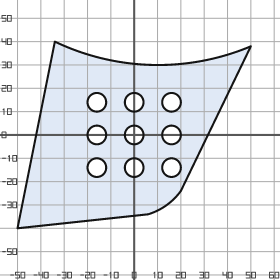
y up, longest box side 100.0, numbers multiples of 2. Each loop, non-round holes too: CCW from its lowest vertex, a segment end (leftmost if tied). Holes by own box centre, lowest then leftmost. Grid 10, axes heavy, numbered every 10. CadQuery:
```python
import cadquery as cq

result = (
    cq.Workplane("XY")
    .moveTo(-50.0, -40.0)
    .lineTo(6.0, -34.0)
    .threePointArc((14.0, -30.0), (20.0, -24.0))
    .lineTo(50.0, 38.0)
    .threePointArc((8.0, 30.0), (-34.0, 40.0))
    .close()
    .moveTo(-16.0, -14.0)
    .circle(4.0)
    .moveTo(0.0, -14.0)
    .circle(4.0)
    .moveTo(16.0, -14.0)
    .circle(4.0)
    .moveTo(-16.0, 0.0)
    .circle(4.0)
    .moveTo(0.0, 0.0)
    .circle(4.0)
    .moveTo(16.0, 0.0)
    .circle(4.0)
    .moveTo(-16.0, 14.0)
    .circle(4.0)
    .moveTo(0.0, 14.0)
    .circle(4.0)
    .moveTo(16.0, 14.0)
    .circle(4.0)
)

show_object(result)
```